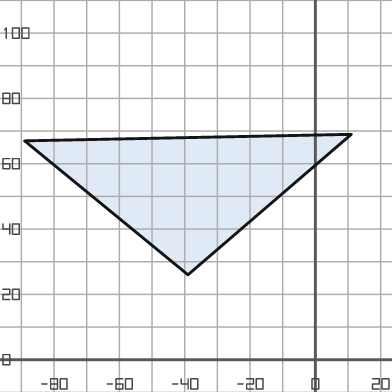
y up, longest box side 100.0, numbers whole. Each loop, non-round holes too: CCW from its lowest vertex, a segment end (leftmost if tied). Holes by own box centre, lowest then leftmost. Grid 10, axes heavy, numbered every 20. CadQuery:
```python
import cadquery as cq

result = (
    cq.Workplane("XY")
    .moveTo(-39.0, 26.0)
    .lineTo(11.0, 69.0)
    .lineTo(-89.0, 67.0)
    .close()
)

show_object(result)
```